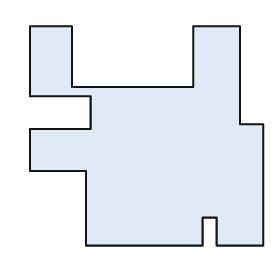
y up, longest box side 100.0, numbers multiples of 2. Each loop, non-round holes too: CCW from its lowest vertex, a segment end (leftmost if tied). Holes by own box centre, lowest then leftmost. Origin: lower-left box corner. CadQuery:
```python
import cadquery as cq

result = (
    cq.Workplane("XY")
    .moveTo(24.0, 0.0)
    .lineTo(74.0, 0.0)
    .lineTo(74.0, 12.0)
    .lineTo(80.0, 12.0)
    .lineTo(80.0, 0.0)
    .lineTo(100.0, 0.0)
    .lineTo(100.0, 52.0)
    .lineTo(90.0, 52.0)
    .lineTo(90.0, 94.0)
    .lineTo(70.0, 94.0)
    .lineTo(70.0, 68.0)
    .lineTo(18.0, 68.0)
    .lineTo(18.0, 94.0)
    .lineTo(0.0, 94.0)
    .lineTo(0.0, 64.0)
    .lineTo(26.0, 64.0)
    .lineTo(26.0, 50.0)
    .lineTo(0.0, 50.0)
    .lineTo(0.0, 32.0)
    .lineTo(24.0, 32.0)
    .close()
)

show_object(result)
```